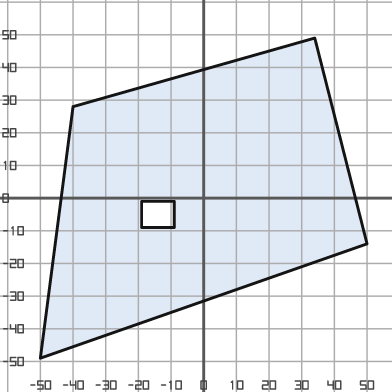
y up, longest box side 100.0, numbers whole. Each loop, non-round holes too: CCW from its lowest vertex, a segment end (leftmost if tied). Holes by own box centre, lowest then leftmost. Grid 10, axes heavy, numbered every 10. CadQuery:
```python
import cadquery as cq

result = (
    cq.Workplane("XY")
    .moveTo(-50.0, -49.0)
    .lineTo(50.0, -14.0)
    .lineTo(34.0, 49.0)
    .lineTo(-40.0, 28.0)
    .close()
    .moveTo(-19.0, -9.0)
    .lineTo(-9.0, -9.0)
    .lineTo(-9.0, -1.0)
    .lineTo(-19.0, -1.0)
    .close()
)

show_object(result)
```